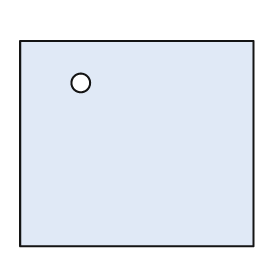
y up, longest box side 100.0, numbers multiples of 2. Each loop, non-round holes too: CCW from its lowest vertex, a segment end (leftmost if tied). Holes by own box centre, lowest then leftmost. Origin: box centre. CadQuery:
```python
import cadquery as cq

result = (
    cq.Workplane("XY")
    .moveTo(-50.0, -44.0)
    .lineTo(50.0, -44.0)
    .lineTo(50.0, 44.0)
    .lineTo(-50.0, 44.0)
    .close()
    .moveTo(-24.0, 26.0)
    .circle(4.0)
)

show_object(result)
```